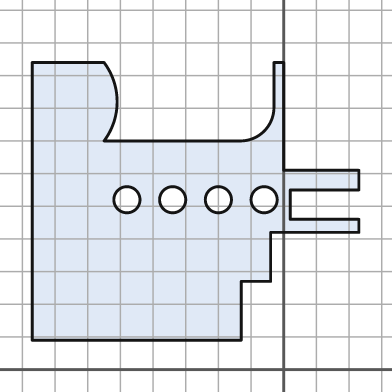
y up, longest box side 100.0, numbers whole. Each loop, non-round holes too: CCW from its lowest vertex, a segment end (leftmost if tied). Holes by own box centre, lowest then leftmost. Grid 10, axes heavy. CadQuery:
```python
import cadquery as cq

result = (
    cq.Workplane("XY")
    .moveTo(-77.0, 9.0)
    .lineTo(-13.0, 9.0)
    .lineTo(-13.0, 27.0)
    .lineTo(-4.0, 27.0)
    .lineTo(-4.0, 42.0)
    .lineTo(23.0, 42.0)
    .lineTo(23.0, 46.0)
    .lineTo(2.0, 46.0)
    .lineTo(2.0, 55.0)
    .lineTo(23.0, 55.0)
    .lineTo(23.0, 61.0)
    .lineTo(0.0, 61.0)
    .lineTo(0.0, 94.0)
    .lineTo(-3.0, 94.0)
    .lineTo(-3.0, 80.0)
    .threePointArc((-6.0, 73.0), (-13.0, 70.0))
    .lineTo(-55.0, 70.0)
    .threePointArc((-51.0, 82.0), (-55.0, 94.0))
    .lineTo(-77.0, 94.0)
    .close()
    .moveTo(-48.0, 52.0)
    .circle(4.0)
    .moveTo(-34.0, 52.0)
    .circle(4.0)
    .moveTo(-20.0, 52.0)
    .circle(4.0)
    .moveTo(-6.0, 52.0)
    .circle(4.0)
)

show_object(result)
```